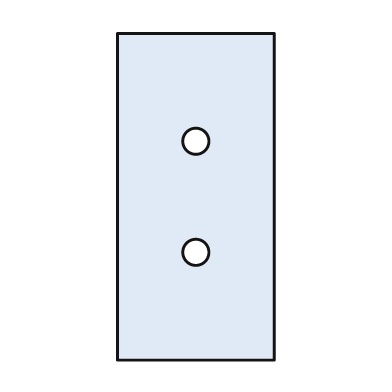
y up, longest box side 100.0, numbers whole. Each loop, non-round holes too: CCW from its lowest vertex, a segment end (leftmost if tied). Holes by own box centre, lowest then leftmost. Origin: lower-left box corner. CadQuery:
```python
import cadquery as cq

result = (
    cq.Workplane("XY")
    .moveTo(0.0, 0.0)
    .lineTo(48.0, 0.0)
    .lineTo(48.0, 100.0)
    .lineTo(0.0, 100.0)
    .close()
    .moveTo(24.0, 33.0)
    .circle(4.0)
    .moveTo(24.0, 67.0)
    .circle(4.0)
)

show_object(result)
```